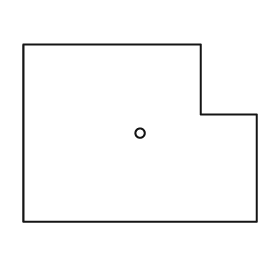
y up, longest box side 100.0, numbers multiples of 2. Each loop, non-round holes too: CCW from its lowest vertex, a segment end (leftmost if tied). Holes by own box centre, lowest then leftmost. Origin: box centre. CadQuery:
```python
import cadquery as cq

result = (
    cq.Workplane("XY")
    .moveTo(-50.0, -38.0)
    .lineTo(50.0, -38.0)
    .lineTo(50.0, 8.0)
    .lineTo(26.0, 8.0)
    .lineTo(26.0, 38.0)
    .lineTo(-50.0, 38.0)
    .close()
    .moveTo(0.0, 0.0)
    .circle(2.0)
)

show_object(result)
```